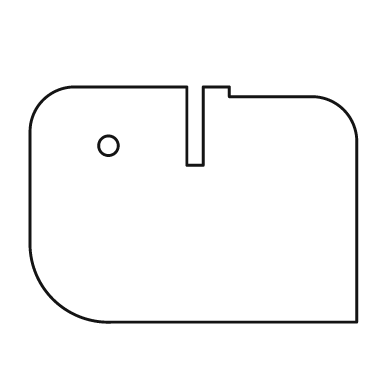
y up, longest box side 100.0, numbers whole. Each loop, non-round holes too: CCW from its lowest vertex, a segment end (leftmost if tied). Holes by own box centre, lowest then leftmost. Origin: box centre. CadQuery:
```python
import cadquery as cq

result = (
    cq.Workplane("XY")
    .moveTo(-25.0, -36.0)
    .lineTo(50.0, -36.0)
    .lineTo(50.0, 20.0)
    .threePointArc((46.0, 29.0), (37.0, 33.0))
    .lineTo(11.0, 33.0)
    .lineTo(11.0, 36.0)
    .lineTo(3.0, 36.0)
    .lineTo(3.0, 12.0)
    .lineTo(-2.0, 12.0)
    .lineTo(-2.0, 36.0)
    .lineTo(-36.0, 36.0)
    .threePointArc((-46.0, 32.0), (-50.0, 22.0))
    .lineTo(-50.0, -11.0)
    .threePointArc((-43.0, -29.0), (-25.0, -36.0))
    .close()
    .moveTo(-26.0, 18.0)
    .circle(3.0)
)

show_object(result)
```